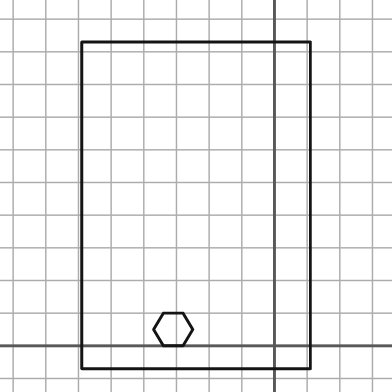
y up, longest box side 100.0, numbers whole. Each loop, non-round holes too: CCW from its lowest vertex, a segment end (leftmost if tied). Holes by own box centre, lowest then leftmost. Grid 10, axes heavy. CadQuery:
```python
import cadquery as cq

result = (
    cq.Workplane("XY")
    .moveTo(-59.0, -7.0)
    .lineTo(11.0, -7.0)
    .lineTo(11.0, 93.0)
    .lineTo(-59.0, 93.0)
    .close()
    .moveTo(-34.0, 0.0)
    .lineTo(-28.0, 0.0)
    .lineTo(-25.0, 5.0)
    .lineTo(-28.0, 10.0)
    .lineTo(-34.0, 10.0)
    .lineTo(-37.0, 5.0)
    .close()
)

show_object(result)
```